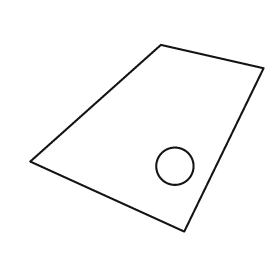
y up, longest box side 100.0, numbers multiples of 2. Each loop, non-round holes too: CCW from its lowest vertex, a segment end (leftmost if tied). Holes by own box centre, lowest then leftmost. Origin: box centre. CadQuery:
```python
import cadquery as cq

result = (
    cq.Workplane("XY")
    .moveTo(16.0, -40.0)
    .lineTo(50.0, 30.0)
    .lineTo(6.0, 40.0)
    .lineTo(-50.0, -10.0)
    .close()
    .moveTo(12.0, -12.0)
    .circle(8.0)
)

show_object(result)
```